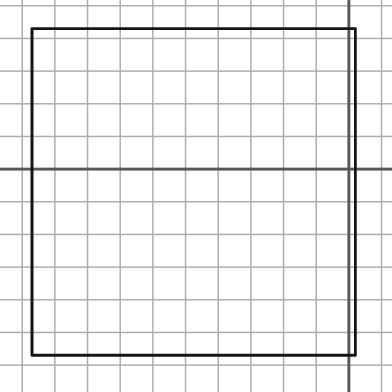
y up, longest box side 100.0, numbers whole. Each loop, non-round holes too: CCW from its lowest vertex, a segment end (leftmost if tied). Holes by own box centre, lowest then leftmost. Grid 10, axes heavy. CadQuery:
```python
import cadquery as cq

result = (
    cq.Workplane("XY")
    .moveTo(-97.0, -57.0)
    .lineTo(2.0, -57.0)
    .lineTo(2.0, 43.0)
    .lineTo(-97.0, 43.0)
    .close()
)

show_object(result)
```